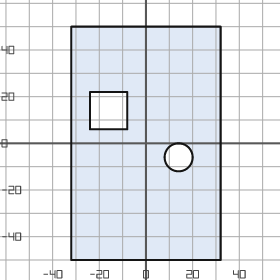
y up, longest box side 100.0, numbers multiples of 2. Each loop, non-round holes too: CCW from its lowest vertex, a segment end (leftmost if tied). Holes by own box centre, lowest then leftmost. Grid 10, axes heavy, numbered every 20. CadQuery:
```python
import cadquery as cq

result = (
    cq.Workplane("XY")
    .moveTo(-32.0, -50.0)
    .lineTo(32.0, -50.0)
    .lineTo(32.0, 50.0)
    .lineTo(-32.0, 50.0)
    .close()
    .moveTo(14.0, -6.0)
    .circle(6.0)
    .moveTo(-24.0, 6.0)
    .lineTo(-8.0, 6.0)
    .lineTo(-8.0, 22.0)
    .lineTo(-24.0, 22.0)
    .close()
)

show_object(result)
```